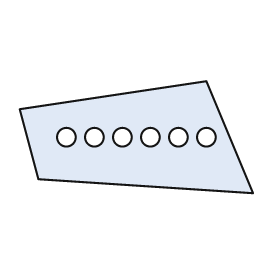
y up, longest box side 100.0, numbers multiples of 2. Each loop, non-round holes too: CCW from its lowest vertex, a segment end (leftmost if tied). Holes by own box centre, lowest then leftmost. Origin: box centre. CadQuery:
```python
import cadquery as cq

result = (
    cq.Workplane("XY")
    .moveTo(50.0, -24.0)
    .lineTo(30.0, 24.0)
    .lineTo(-50.0, 12.0)
    .lineTo(-42.0, -18.0)
    .close()
    .moveTo(-30.0, 0.0)
    .circle(4.0)
    .moveTo(-18.0, 0.0)
    .circle(4.0)
    .moveTo(-6.0, 0.0)
    .circle(4.0)
    .moveTo(6.0, 0.0)
    .circle(4.0)
    .moveTo(18.0, 0.0)
    .circle(4.0)
    .moveTo(30.0, 0.0)
    .circle(4.0)
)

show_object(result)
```